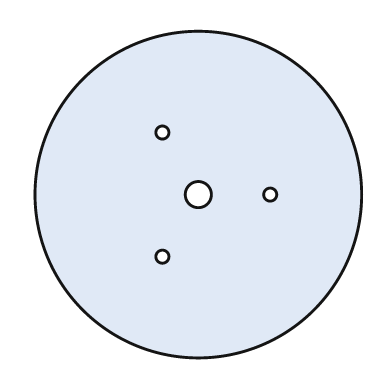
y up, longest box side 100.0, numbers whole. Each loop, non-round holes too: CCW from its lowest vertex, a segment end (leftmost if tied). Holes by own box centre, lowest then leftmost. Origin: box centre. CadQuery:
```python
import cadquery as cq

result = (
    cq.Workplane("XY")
    .moveTo(0.0, 0.0)
    .circle(50.0)
    .moveTo(-11.0, -19.0)
    .circle(2.0)
    .moveTo(0.0, 0.0)
    .circle(4.0)
    .moveTo(22.0, 0.0)
    .circle(2.0)
    .moveTo(-11.0, 19.0)
    .circle(2.0)
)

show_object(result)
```